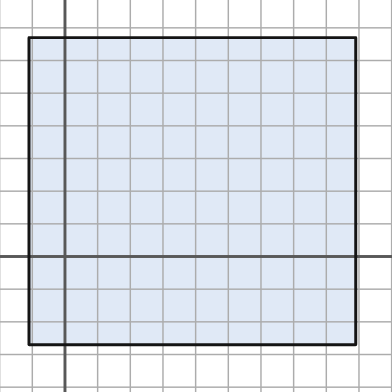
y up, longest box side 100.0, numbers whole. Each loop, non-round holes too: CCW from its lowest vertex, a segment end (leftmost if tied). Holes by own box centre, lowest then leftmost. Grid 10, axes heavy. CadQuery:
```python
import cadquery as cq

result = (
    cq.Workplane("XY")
    .moveTo(-11.0, -27.0)
    .lineTo(89.0, -27.0)
    .lineTo(89.0, 67.0)
    .lineTo(-11.0, 67.0)
    .close()
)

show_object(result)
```